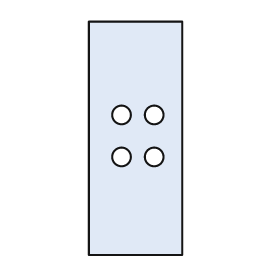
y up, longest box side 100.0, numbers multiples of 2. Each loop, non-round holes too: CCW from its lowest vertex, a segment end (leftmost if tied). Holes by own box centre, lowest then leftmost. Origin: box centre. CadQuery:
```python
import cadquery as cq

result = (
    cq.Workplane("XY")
    .moveTo(-20.0, -50.0)
    .lineTo(20.0, -50.0)
    .lineTo(20.0, 50.0)
    .lineTo(-20.0, 50.0)
    .close()
    .moveTo(-6.0, -8.0)
    .circle(4.0)
    .moveTo(8.0, -8.0)
    .circle(4.0)
    .moveTo(-6.0, 10.0)
    .circle(4.0)
    .moveTo(8.0, 10.0)
    .circle(4.0)
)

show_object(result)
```